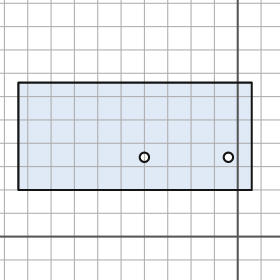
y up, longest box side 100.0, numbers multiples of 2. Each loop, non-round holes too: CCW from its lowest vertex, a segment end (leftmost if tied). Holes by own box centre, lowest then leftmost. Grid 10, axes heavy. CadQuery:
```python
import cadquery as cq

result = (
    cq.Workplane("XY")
    .moveTo(-94.0, 20.0)
    .lineTo(6.0, 20.0)
    .lineTo(6.0, 66.0)
    .lineTo(-94.0, 66.0)
    .close()
    .moveTo(-40.0, 34.0)
    .circle(2.0)
    .moveTo(-4.0, 34.0)
    .circle(2.0)
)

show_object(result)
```